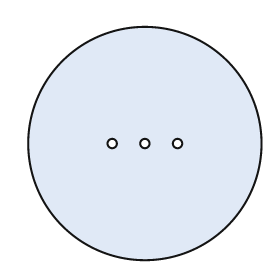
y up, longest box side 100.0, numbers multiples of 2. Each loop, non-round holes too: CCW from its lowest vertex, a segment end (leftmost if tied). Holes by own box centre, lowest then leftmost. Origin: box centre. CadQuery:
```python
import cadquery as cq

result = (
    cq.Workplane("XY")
    .moveTo(0.0, 0.0)
    .circle(50.0)
    .moveTo(-14.0, 0.0)
    .circle(2.0)
    .moveTo(0.0, 0.0)
    .circle(2.0)
    .moveTo(14.0, 0.0)
    .circle(2.0)
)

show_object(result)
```